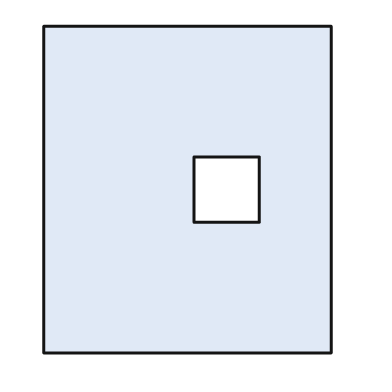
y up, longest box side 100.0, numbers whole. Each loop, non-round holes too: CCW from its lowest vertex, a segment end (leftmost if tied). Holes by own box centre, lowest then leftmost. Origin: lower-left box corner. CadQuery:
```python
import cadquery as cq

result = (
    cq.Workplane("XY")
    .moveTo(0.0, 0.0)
    .lineTo(88.0, 0.0)
    .lineTo(88.0, 100.0)
    .lineTo(0.0, 100.0)
    .close()
    .moveTo(46.0, 40.0)
    .lineTo(66.0, 40.0)
    .lineTo(66.0, 60.0)
    .lineTo(46.0, 60.0)
    .close()
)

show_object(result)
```